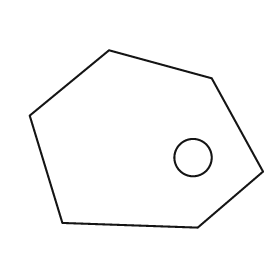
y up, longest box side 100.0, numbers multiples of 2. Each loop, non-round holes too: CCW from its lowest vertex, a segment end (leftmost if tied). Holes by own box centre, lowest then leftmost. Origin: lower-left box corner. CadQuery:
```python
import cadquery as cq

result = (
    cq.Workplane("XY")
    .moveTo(72.0, 0.0)
    .lineTo(100.0, 24.0)
    .lineTo(78.0, 64.0)
    .lineTo(34.0, 76.0)
    .lineTo(0.0, 48.0)
    .lineTo(14.0, 2.0)
    .close()
    .moveTo(70.0, 30.0)
    .circle(8.0)
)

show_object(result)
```